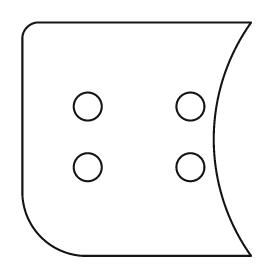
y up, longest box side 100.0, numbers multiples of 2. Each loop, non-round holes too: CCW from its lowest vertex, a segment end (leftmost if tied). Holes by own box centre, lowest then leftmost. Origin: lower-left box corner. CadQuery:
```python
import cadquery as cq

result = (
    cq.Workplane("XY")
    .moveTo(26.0, 0.0)
    .lineTo(98.0, 0.0)
    .threePointArc((82.0, 50.0), (98.0, 100.0))
    .lineTo(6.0, 100.0)
    .threePointArc((2.0, 98.0), (0.0, 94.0))
    .lineTo(0.0, 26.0)
    .threePointArc((8.0, 8.0), (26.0, 0.0))
    .close()
    .moveTo(28.0, 38.0)
    .circle(6.0)
    .moveTo(72.0, 38.0)
    .circle(6.0)
    .moveTo(28.0, 64.0)
    .circle(6.0)
    .moveTo(72.0, 64.0)
    .circle(6.0)
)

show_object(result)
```